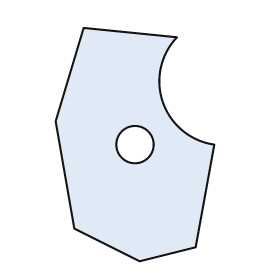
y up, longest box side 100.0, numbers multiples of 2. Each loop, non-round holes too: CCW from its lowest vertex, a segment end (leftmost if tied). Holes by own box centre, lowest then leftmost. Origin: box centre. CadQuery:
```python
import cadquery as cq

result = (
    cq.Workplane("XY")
    .moveTo(2.0, -50.0)
    .lineTo(26.0, -44.0)
    .lineTo(34.0, 0.0)
    .threePointArc((12.0, 18.0), (18.0, 46.0))
    .lineTo(-22.0, 50.0)
    .lineTo(-34.0, 10.0)
    .lineTo(-26.0, -36.0)
    .close()
    .moveTo(0.0, 0.0)
    .circle(8.0)
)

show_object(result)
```